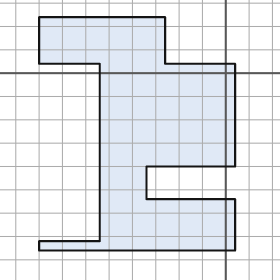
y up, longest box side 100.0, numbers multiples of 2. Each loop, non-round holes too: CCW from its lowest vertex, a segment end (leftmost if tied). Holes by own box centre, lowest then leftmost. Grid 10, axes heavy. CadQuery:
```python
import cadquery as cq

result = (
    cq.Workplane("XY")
    .moveTo(-80.0, -76.0)
    .lineTo(4.0, -76.0)
    .lineTo(4.0, -54.0)
    .lineTo(-34.0, -54.0)
    .lineTo(-34.0, -40.0)
    .lineTo(4.0, -40.0)
    .lineTo(4.0, 4.0)
    .lineTo(-26.0, 4.0)
    .lineTo(-26.0, 24.0)
    .lineTo(-80.0, 24.0)
    .lineTo(-80.0, 4.0)
    .lineTo(-54.0, 4.0)
    .lineTo(-54.0, -72.0)
    .lineTo(-80.0, -72.0)
    .close()
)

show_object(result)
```